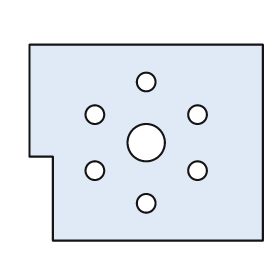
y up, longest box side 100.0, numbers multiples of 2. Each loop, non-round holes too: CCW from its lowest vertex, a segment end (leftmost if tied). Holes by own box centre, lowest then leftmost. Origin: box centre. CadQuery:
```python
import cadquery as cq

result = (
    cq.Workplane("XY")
    .moveTo(-40.0, -42.0)
    .lineTo(50.0, -42.0)
    .lineTo(50.0, 42.0)
    .lineTo(-50.0, 42.0)
    .lineTo(-50.0, -6.0)
    .lineTo(-40.0, -6.0)
    .close()
    .moveTo(0.0, -26.0)
    .circle(4.0)
    .moveTo(-22.0, -12.0)
    .circle(4.0)
    .moveTo(22.0, -12.0)
    .circle(4.0)
    .moveTo(0.0, 0.0)
    .circle(8.0)
    .moveTo(-22.0, 12.0)
    .circle(4.0)
    .moveTo(22.0, 12.0)
    .circle(4.0)
    .moveTo(0.0, 26.0)
    .circle(4.0)
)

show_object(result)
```